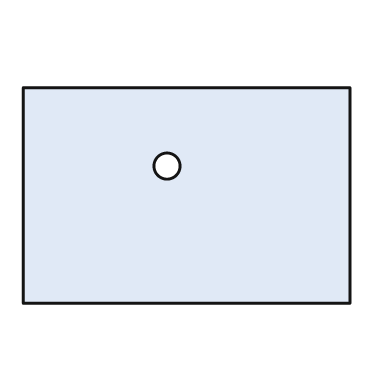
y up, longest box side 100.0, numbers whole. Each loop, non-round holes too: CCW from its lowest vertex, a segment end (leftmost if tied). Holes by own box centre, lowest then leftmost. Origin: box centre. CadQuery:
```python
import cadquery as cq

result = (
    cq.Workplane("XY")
    .moveTo(-50.0, -33.0)
    .lineTo(50.0, -33.0)
    .lineTo(50.0, 33.0)
    .lineTo(-50.0, 33.0)
    .close()
    .moveTo(-6.0, 9.0)
    .circle(4.0)
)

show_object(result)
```